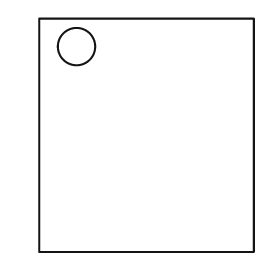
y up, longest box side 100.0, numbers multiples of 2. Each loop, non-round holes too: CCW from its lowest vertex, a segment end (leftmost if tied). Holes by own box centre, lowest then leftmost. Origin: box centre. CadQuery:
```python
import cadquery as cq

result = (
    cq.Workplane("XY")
    .moveTo(-46.0, -50.0)
    .lineTo(46.0, -50.0)
    .lineTo(46.0, 50.0)
    .lineTo(-46.0, 50.0)
    .close()
    .moveTo(-30.0, 38.0)
    .circle(8.0)
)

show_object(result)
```